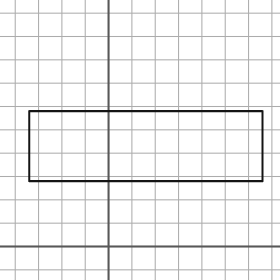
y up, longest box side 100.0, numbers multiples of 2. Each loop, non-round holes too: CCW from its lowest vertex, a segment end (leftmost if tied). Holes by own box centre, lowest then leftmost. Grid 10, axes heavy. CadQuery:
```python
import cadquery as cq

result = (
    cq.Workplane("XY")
    .moveTo(-34.0, 28.0)
    .lineTo(66.0, 28.0)
    .lineTo(66.0, 58.0)
    .lineTo(-34.0, 58.0)
    .close()
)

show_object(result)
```